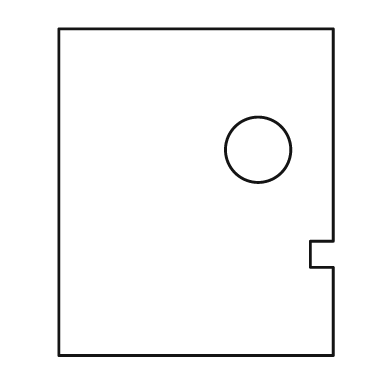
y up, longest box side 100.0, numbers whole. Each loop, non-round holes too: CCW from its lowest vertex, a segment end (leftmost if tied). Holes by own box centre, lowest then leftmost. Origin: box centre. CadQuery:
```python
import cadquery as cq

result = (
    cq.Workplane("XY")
    .moveTo(-42.0, -50.0)
    .lineTo(42.0, -50.0)
    .lineTo(42.0, -23.0)
    .lineTo(35.0, -23.0)
    .lineTo(35.0, -15.0)
    .lineTo(42.0, -15.0)
    .lineTo(42.0, 50.0)
    .lineTo(-42.0, 50.0)
    .close()
    .moveTo(19.0, 13.0)
    .circle(10.0)
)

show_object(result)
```